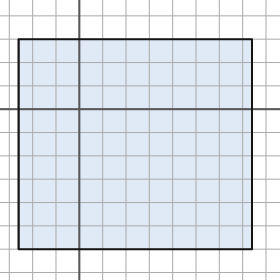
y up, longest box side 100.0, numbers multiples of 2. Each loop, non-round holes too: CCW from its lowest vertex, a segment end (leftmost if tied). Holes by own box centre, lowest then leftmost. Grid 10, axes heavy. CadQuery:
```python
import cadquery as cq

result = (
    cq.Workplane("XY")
    .moveTo(-26.0, -60.0)
    .lineTo(74.0, -60.0)
    .lineTo(74.0, 30.0)
    .lineTo(-26.0, 30.0)
    .close()
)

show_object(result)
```